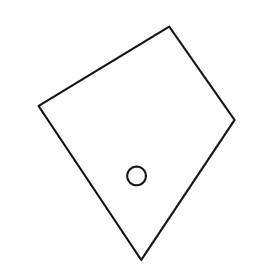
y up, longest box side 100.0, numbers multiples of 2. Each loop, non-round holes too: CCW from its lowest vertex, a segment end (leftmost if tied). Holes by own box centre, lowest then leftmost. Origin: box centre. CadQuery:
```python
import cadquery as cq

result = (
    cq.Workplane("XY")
    .moveTo(2.0, -50.0)
    .lineTo(42.0, 10.0)
    .lineTo(14.0, 50.0)
    .lineTo(-42.0, 16.0)
    .close()
    .moveTo(0.0, -14.0)
    .circle(4.0)
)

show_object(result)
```